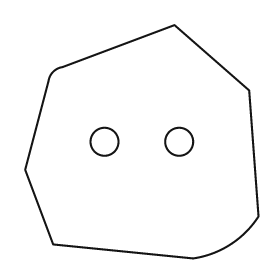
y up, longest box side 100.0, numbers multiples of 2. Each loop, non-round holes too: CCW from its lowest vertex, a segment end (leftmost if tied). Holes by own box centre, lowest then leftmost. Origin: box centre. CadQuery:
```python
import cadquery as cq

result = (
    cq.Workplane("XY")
    .moveTo(22.0, -50.0)
    .threePointArc((38.0, -44.0), (50.0, -32.0))
    .lineTo(46.0, 22.0)
    .lineTo(14.0, 50.0)
    .lineTo(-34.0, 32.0)
    .threePointArc((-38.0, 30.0), (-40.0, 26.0))
    .lineTo(-50.0, -12.0)
    .lineTo(-38.0, -44.0)
    .close()
    .moveTo(-16.0, 0.0)
    .circle(6.0)
    .moveTo(16.0, 0.0)
    .circle(6.0)
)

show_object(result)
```